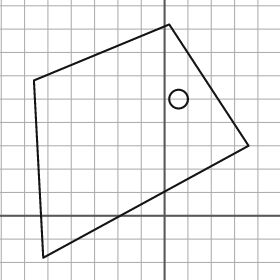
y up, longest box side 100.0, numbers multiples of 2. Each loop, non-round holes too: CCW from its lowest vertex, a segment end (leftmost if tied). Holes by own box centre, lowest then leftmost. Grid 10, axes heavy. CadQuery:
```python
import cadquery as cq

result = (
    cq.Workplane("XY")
    .moveTo(-52.0, -18.0)
    .lineTo(36.0, 30.0)
    .lineTo(2.0, 82.0)
    .lineTo(-56.0, 58.0)
    .close()
    .moveTo(6.0, 50.0)
    .circle(4.0)
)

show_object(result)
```